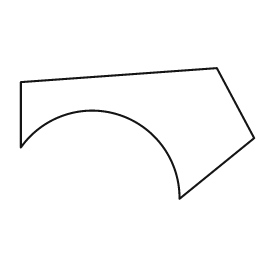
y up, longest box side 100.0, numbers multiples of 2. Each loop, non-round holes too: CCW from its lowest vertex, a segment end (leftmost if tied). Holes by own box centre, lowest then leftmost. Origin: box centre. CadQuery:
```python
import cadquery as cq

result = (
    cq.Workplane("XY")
    .moveTo(18.0, -28.0)
    .lineTo(50.0, -2.0)
    .lineTo(34.0, 28.0)
    .lineTo(-50.0, 22.0)
    .lineTo(-50.0, -6.0)
    .threePointArc((-8.0, 8.0), (18.0, -28.0))
    .close()
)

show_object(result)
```